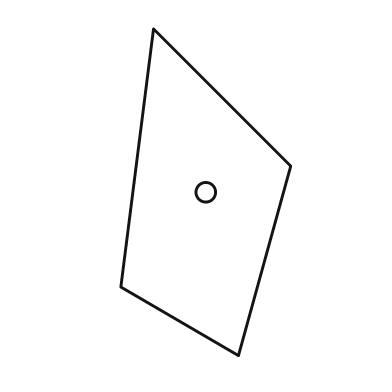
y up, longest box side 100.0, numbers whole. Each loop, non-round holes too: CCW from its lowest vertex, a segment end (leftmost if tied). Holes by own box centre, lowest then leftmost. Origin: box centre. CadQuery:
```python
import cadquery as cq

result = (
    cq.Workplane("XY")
    .moveTo(10.0, -50.0)
    .lineTo(26.0, 8.0)
    .lineTo(-16.0, 50.0)
    .lineTo(-26.0, -29.0)
    .close()
    .moveTo(0.0, 0.0)
    .circle(3.0)
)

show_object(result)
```